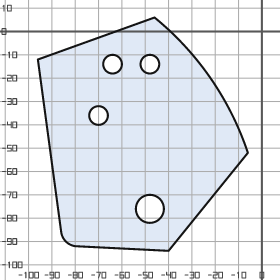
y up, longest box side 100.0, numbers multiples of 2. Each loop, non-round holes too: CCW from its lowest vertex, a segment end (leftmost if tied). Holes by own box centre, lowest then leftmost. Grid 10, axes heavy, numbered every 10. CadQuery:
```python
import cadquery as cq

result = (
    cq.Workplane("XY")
    .moveTo(-40.0, -94.0)
    .lineTo(-6.0, -52.0)
    .threePointArc((-22.0, -20.0), (-46.0, 6.0))
    .lineTo(-96.0, -12.0)
    .lineTo(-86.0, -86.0)
    .threePointArc((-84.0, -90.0), (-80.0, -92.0))
    .close()
    .moveTo(-48.0, -76.0)
    .circle(6.0)
    .moveTo(-70.0, -36.0)
    .circle(4.0)
    .moveTo(-64.0, -14.0)
    .circle(4.0)
    .moveTo(-48.0, -14.0)
    .circle(4.0)
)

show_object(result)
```